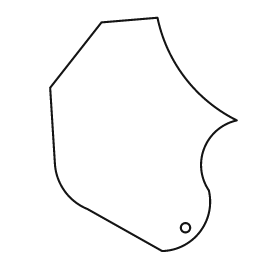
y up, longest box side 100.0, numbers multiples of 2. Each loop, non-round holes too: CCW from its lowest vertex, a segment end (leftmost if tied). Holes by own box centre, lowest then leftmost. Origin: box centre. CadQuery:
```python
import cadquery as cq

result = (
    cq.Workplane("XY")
    .moveTo(8.0, -50.0)
    .threePointArc((24.0, -42.0), (28.0, -24.0))
    .threePointArc((26.0, -6.0), (40.0, 6.0))
    .threePointArc((18.0, 24.0), (6.0, 50.0))
    .lineTo(-18.0, 48.0)
    .lineTo(-40.0, 20.0)
    .lineTo(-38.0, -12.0)
    .threePointArc((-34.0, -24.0), (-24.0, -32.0))
    .close()
    .moveTo(18.0, -40.0)
    .circle(2.0)
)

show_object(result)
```